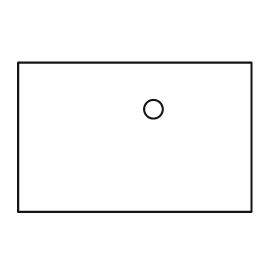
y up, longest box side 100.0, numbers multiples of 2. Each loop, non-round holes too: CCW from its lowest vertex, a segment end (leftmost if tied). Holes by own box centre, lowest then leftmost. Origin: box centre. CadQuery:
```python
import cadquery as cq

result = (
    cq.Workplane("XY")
    .moveTo(-50.0, -32.0)
    .lineTo(50.0, -32.0)
    .lineTo(50.0, 32.0)
    .lineTo(-50.0, 32.0)
    .close()
    .moveTo(8.0, 12.0)
    .circle(4.0)
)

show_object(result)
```